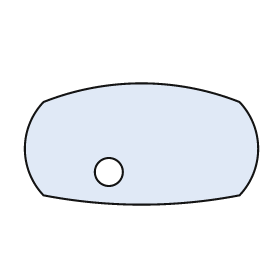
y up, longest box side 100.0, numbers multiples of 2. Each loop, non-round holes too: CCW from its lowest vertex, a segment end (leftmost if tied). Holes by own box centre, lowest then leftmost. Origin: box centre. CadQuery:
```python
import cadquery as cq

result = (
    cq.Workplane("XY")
    .moveTo(-42.0, -22.0)
    .threePointArc((0.0, -26.0), (42.0, -22.0))
    .threePointArc((50.0, -2.0), (42.0, 18.0))
    .threePointArc((0.0, 26.0), (-42.0, 18.0))
    .threePointArc((-50.0, -2.0), (-42.0, -22.0))
    .close()
    .moveTo(-14.0, -12.0)
    .circle(6.0)
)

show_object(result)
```